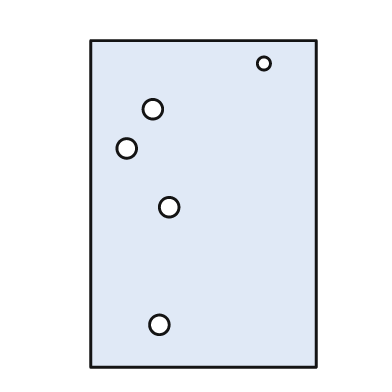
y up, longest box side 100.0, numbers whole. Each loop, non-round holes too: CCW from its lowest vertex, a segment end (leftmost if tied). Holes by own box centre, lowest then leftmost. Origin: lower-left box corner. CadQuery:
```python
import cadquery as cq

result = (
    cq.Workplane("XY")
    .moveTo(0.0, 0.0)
    .lineTo(69.0, 0.0)
    .lineTo(69.0, 100.0)
    .lineTo(0.0, 100.0)
    .close()
    .moveTo(21.0, 13.0)
    .circle(3.0)
    .moveTo(24.0, 49.0)
    .circle(3.0)
    .moveTo(11.0, 67.0)
    .circle(3.0)
    .moveTo(19.0, 79.0)
    .circle(3.0)
    .moveTo(53.0, 93.0)
    .circle(2.0)
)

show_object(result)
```